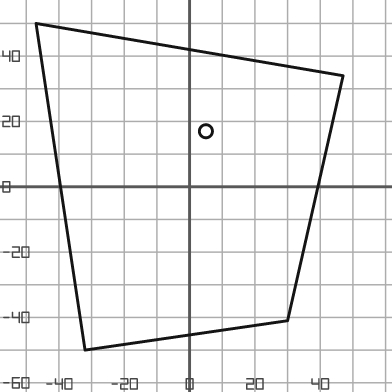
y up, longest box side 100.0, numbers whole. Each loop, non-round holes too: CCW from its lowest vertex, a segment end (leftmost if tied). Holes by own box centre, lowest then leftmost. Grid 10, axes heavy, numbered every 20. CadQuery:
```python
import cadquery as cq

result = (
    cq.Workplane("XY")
    .moveTo(-32.0, -50.0)
    .lineTo(30.0, -41.0)
    .lineTo(47.0, 34.0)
    .lineTo(-47.0, 50.0)
    .close()
    .moveTo(5.0, 17.0)
    .circle(2.0)
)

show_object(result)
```